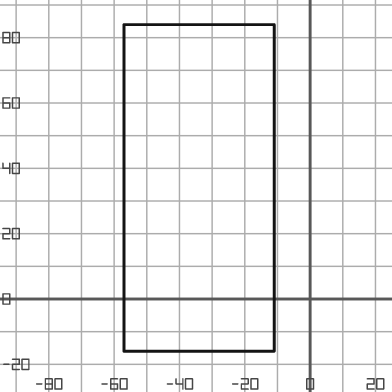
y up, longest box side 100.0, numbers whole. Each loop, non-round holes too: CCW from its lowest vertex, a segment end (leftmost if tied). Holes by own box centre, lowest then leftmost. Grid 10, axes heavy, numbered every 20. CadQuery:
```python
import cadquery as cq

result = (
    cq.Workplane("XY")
    .moveTo(-57.0, -16.0)
    .lineTo(-11.0, -16.0)
    .lineTo(-11.0, 84.0)
    .lineTo(-57.0, 84.0)
    .close()
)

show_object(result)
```